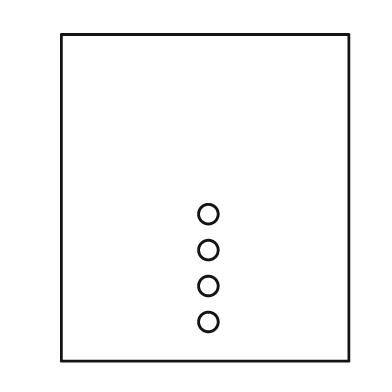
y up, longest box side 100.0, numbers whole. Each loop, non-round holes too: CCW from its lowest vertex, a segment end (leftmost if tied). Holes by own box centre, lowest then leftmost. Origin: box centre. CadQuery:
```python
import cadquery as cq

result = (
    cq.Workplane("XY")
    .moveTo(-44.0, -50.0)
    .lineTo(44.0, -50.0)
    .lineTo(44.0, 50.0)
    .lineTo(-44.0, 50.0)
    .close()
    .moveTo(1.0, -38.0)
    .circle(3.0)
    .moveTo(1.0, -27.0)
    .circle(3.0)
    .moveTo(1.0, -16.0)
    .circle(3.0)
    .moveTo(1.0, -5.0)
    .circle(3.0)
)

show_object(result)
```